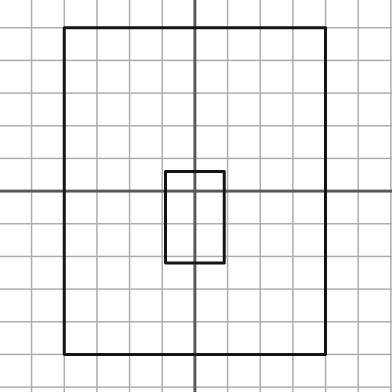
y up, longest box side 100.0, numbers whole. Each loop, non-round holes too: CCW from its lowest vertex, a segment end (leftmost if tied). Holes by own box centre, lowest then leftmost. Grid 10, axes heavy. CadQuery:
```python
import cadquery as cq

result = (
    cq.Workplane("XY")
    .moveTo(-40.0, -50.0)
    .lineTo(40.0, -50.0)
    .lineTo(40.0, 50.0)
    .lineTo(-40.0, 50.0)
    .close()
    .moveTo(-9.0, -22.0)
    .lineTo(9.0, -22.0)
    .lineTo(9.0, 6.0)
    .lineTo(-9.0, 6.0)
    .close()
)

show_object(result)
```